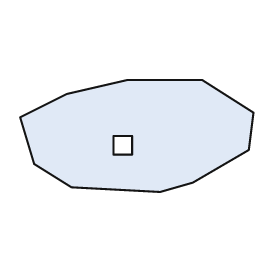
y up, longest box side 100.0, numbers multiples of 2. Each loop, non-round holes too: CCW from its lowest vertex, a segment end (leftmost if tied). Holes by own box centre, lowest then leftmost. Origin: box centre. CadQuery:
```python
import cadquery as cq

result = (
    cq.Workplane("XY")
    .moveTo(10.0, -24.0)
    .lineTo(24.0, -20.0)
    .lineTo(48.0, -6.0)
    .lineTo(50.0, 10.0)
    .lineTo(28.0, 24.0)
    .lineTo(-4.0, 24.0)
    .lineTo(-30.0, 18.0)
    .lineTo(-50.0, 8.0)
    .lineTo(-44.0, -12.0)
    .lineTo(-28.0, -22.0)
    .close()
    .moveTo(-10.0, -8.0)
    .lineTo(-2.0, -8.0)
    .lineTo(-2.0, 0.0)
    .lineTo(-10.0, 0.0)
    .close()
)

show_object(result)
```